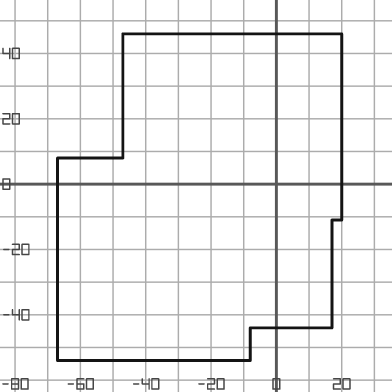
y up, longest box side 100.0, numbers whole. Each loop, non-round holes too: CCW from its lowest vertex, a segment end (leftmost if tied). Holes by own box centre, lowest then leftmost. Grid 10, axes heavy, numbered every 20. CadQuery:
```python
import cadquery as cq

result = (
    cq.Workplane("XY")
    .moveTo(-67.0, -54.0)
    .lineTo(-8.0, -54.0)
    .lineTo(-8.0, -44.0)
    .lineTo(17.0, -44.0)
    .lineTo(17.0, -11.0)
    .lineTo(20.0, -11.0)
    .lineTo(20.0, 46.0)
    .lineTo(-47.0, 46.0)
    .lineTo(-47.0, 8.0)
    .lineTo(-67.0, 8.0)
    .close()
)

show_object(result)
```